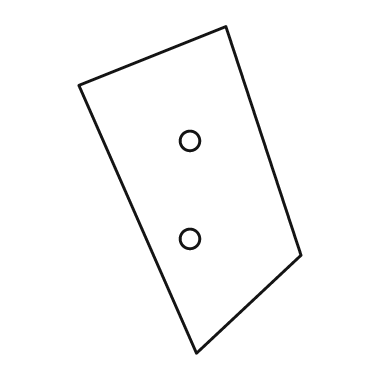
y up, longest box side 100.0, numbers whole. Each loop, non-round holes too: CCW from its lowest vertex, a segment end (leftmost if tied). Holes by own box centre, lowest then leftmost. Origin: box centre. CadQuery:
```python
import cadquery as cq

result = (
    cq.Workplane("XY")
    .moveTo(2.0, -50.0)
    .lineTo(34.0, -20.0)
    .lineTo(11.0, 50.0)
    .lineTo(-34.0, 32.0)
    .close()
    .moveTo(0.0, -15.0)
    .circle(3.0)
    .moveTo(0.0, 15.0)
    .circle(3.0)
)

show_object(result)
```